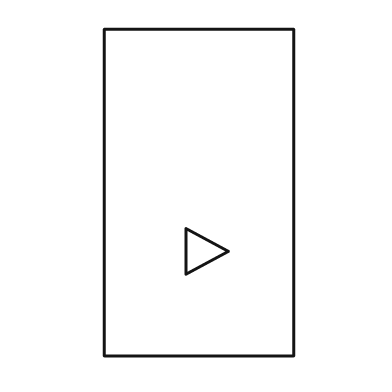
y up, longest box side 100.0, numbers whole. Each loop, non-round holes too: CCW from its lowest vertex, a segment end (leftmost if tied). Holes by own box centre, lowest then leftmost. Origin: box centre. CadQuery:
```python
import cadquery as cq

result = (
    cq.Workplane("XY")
    .moveTo(-29.0, -50.0)
    .lineTo(29.0, -50.0)
    .lineTo(29.0, 50.0)
    .lineTo(-29.0, 50.0)
    .close()
    .moveTo(-4.0, -25.0)
    .lineTo(9.0, -18.0)
    .lineTo(-4.0, -11.0)
    .close()
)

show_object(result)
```